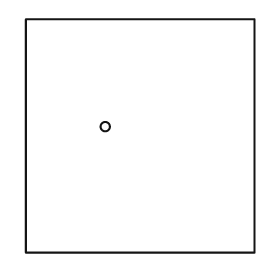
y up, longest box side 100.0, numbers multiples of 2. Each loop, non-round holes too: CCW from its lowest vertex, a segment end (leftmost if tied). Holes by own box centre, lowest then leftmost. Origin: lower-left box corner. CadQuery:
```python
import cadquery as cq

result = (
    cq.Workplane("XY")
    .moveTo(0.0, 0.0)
    .lineTo(98.0, 0.0)
    .lineTo(98.0, 100.0)
    .lineTo(0.0, 100.0)
    .close()
    .moveTo(34.0, 54.0)
    .circle(2.0)
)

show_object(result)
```